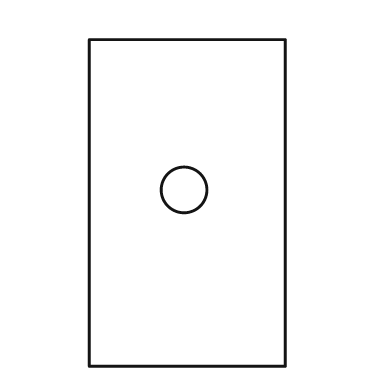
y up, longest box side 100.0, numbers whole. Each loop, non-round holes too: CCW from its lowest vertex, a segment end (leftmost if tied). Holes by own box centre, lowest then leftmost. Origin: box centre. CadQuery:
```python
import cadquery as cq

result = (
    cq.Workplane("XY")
    .moveTo(-30.0, -50.0)
    .lineTo(30.0, -50.0)
    .lineTo(30.0, 50.0)
    .lineTo(-30.0, 50.0)
    .close()
    .moveTo(-1.0, 4.0)
    .circle(7.0)
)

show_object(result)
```